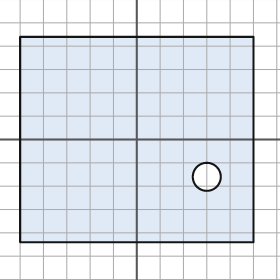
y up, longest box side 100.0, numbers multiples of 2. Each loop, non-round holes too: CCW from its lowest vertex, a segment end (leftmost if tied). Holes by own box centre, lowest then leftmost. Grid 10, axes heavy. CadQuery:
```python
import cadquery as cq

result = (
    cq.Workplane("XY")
    .moveTo(-50.0, -44.0)
    .lineTo(50.0, -44.0)
    .lineTo(50.0, 44.0)
    .lineTo(-50.0, 44.0)
    .close()
    .moveTo(30.0, -16.0)
    .circle(6.0)
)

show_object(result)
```